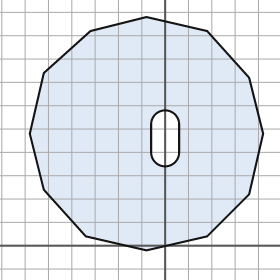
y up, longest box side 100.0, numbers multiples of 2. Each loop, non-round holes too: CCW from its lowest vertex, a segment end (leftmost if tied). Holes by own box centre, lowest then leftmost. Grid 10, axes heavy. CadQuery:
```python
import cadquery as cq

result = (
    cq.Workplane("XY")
    .moveTo(-8.0, -2.0)
    .lineTo(18.0, 4.0)
    .lineTo(36.0, 22.0)
    .lineTo(42.0, 48.0)
    .lineTo(36.0, 72.0)
    .lineTo(18.0, 92.0)
    .lineTo(-8.0, 98.0)
    .lineTo(-32.0, 92.0)
    .lineTo(-52.0, 74.0)
    .lineTo(-58.0, 48.0)
    .lineTo(-52.0, 24.0)
    .lineTo(-34.0, 4.0)
    .close()
    .moveTo(-6.0, 40.0)
    .threePointArc((0.0, 34.0), (6.0, 40.0))
    .lineTo(6.0, 52.0)
    .threePointArc((0.0, 58.0), (-6.0, 52.0))
    .close()
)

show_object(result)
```